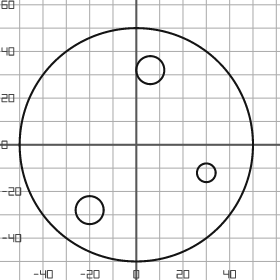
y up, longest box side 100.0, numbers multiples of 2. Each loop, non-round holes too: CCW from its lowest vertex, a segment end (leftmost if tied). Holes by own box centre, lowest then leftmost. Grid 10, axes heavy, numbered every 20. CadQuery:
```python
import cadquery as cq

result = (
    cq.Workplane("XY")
    .moveTo(0.0, 0.0)
    .circle(50.0)
    .moveTo(-20.0, -28.0)
    .circle(6.0)
    .moveTo(30.0, -12.0)
    .circle(4.0)
    .moveTo(6.0, 32.0)
    .circle(6.0)
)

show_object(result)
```